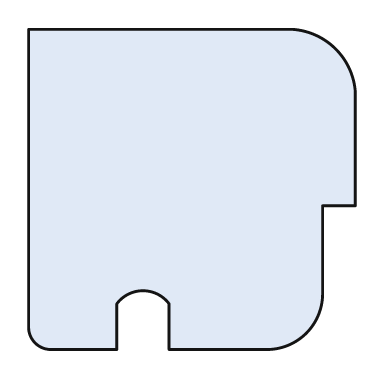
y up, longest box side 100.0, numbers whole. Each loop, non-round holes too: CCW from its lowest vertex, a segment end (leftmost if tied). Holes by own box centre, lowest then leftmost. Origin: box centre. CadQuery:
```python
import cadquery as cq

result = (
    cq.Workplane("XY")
    .moveTo(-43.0, -49.0)
    .lineTo(-23.0, -49.0)
    .lineTo(-23.0, -35.0)
    .threePointArc((-15.0, -31.0), (-7.0, -35.0))
    .lineTo(-7.0, -49.0)
    .lineTo(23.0, -49.0)
    .threePointArc((35.0, -44.0), (40.0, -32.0))
    .lineTo(40.0, -5.0)
    .lineTo(50.0, -5.0)
    .lineTo(50.0, 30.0)
    .threePointArc((44.0, 43.0), (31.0, 49.0))
    .lineTo(-50.0, 49.0)
    .lineTo(-50.0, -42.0)
    .threePointArc((-48.0, -47.0), (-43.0, -49.0))
    .close()
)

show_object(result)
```